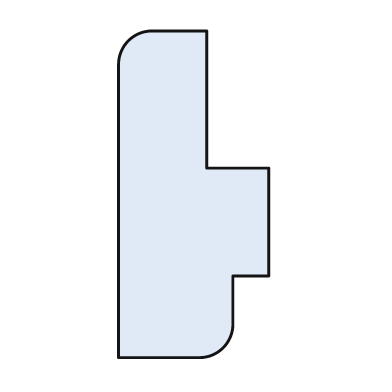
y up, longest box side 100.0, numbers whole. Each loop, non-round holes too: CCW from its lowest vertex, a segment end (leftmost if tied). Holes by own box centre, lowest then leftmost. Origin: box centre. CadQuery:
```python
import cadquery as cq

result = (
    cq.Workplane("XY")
    .moveTo(-23.0, -50.0)
    .lineTo(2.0, -50.0)
    .threePointArc((9.0, -47.0), (12.0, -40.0))
    .lineTo(12.0, -25.0)
    .lineTo(23.0, -25.0)
    .lineTo(23.0, 8.0)
    .lineTo(4.0, 8.0)
    .lineTo(4.0, 50.0)
    .lineTo(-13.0, 50.0)
    .threePointArc((-20.0, 47.0), (-23.0, 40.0))
    .close()
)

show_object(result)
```